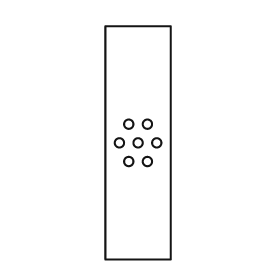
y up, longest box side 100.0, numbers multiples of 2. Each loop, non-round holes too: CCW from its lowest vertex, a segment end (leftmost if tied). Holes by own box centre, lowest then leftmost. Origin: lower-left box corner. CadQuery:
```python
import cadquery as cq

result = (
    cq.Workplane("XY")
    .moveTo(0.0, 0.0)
    .lineTo(28.0, 0.0)
    .lineTo(28.0, 100.0)
    .lineTo(0.0, 100.0)
    .close()
    .moveTo(10.0, 42.0)
    .circle(2.0)
    .moveTo(18.0, 42.0)
    .circle(2.0)
    .moveTo(6.0, 50.0)
    .circle(2.0)
    .moveTo(14.0, 50.0)
    .circle(2.0)
    .moveTo(22.0, 50.0)
    .circle(2.0)
    .moveTo(10.0, 58.0)
    .circle(2.0)
    .moveTo(18.0, 58.0)
    .circle(2.0)
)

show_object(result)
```